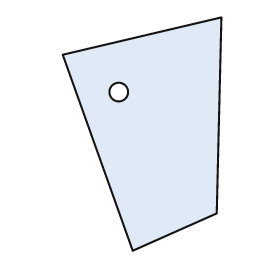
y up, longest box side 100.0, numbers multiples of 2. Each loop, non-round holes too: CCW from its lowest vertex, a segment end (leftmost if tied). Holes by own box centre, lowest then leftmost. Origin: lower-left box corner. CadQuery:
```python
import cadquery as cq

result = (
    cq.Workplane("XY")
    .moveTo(30.0, 0.0)
    .lineTo(66.0, 16.0)
    .lineTo(68.0, 100.0)
    .lineTo(0.0, 84.0)
    .close()
    .moveTo(24.0, 68.0)
    .circle(4.0)
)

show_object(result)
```